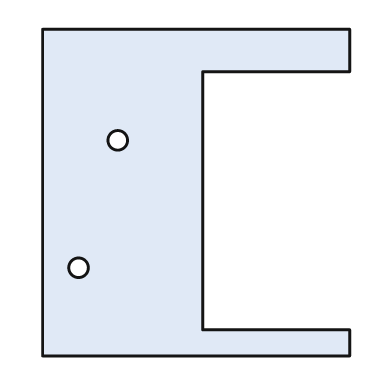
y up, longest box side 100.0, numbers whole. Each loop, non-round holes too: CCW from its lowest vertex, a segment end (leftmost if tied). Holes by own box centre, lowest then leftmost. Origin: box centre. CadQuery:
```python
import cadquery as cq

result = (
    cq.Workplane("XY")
    .moveTo(-47.0, -50.0)
    .lineTo(47.0, -50.0)
    .lineTo(47.0, -42.0)
    .lineTo(2.0, -42.0)
    .lineTo(2.0, 37.0)
    .lineTo(47.0, 37.0)
    .lineTo(47.0, 50.0)
    .lineTo(-47.0, 50.0)
    .close()
    .moveTo(-36.0, -23.0)
    .circle(3.0)
    .moveTo(-24.0, 16.0)
    .circle(3.0)
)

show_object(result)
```